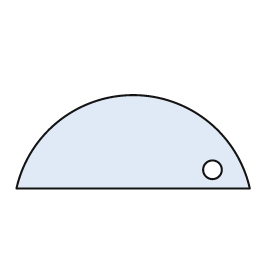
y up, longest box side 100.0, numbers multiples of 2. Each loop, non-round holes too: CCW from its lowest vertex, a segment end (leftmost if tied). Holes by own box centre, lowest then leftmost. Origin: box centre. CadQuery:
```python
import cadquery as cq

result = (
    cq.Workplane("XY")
    .moveTo(-50.0, -20.0)
    .lineTo(50.0, -20.0)
    .threePointArc((0.0, 20.0), (-50.0, -20.0))
    .close()
    .moveTo(34.0, -12.0)
    .circle(4.0)
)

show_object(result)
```